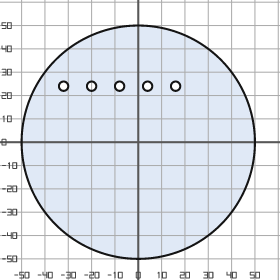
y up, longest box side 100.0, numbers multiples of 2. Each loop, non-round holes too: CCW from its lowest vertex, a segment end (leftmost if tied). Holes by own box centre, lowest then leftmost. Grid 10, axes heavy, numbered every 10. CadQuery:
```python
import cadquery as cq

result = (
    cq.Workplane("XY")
    .moveTo(0.0, 0.0)
    .circle(50.0)
    .moveTo(-32.0, 24.0)
    .circle(2.0)
    .moveTo(-20.0, 24.0)
    .circle(2.0)
    .moveTo(-8.0, 24.0)
    .circle(2.0)
    .moveTo(4.0, 24.0)
    .circle(2.0)
    .moveTo(16.0, 24.0)
    .circle(2.0)
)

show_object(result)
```